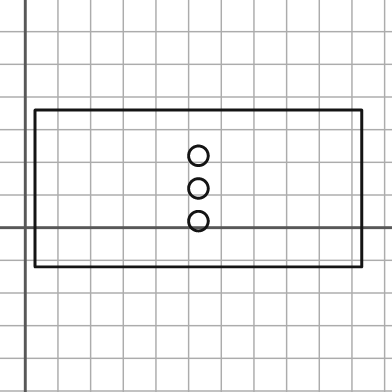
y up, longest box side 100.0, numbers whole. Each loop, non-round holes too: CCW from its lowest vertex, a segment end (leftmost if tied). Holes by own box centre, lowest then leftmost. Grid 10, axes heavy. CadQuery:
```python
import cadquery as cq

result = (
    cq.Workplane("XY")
    .moveTo(3.0, -12.0)
    .lineTo(103.0, -12.0)
    .lineTo(103.0, 36.0)
    .lineTo(3.0, 36.0)
    .close()
    .moveTo(53.0, 2.0)
    .circle(3.0)
    .moveTo(53.0, 12.0)
    .circle(3.0)
    .moveTo(53.0, 22.0)
    .circle(3.0)
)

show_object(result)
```